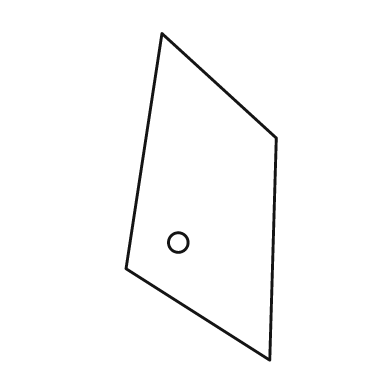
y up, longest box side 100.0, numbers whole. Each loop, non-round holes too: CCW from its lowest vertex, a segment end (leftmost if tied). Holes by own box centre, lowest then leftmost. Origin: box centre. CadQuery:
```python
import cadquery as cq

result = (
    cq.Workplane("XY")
    .moveTo(21.0, -50.0)
    .lineTo(23.0, 18.0)
    .lineTo(-12.0, 50.0)
    .lineTo(-23.0, -22.0)
    .close()
    .moveTo(-7.0, -14.0)
    .circle(3.0)
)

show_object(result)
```